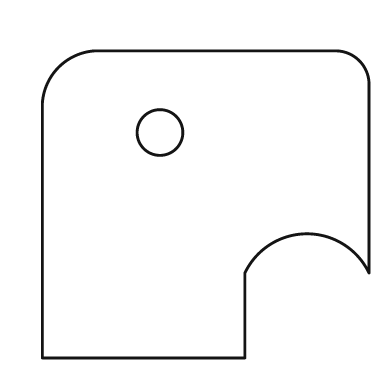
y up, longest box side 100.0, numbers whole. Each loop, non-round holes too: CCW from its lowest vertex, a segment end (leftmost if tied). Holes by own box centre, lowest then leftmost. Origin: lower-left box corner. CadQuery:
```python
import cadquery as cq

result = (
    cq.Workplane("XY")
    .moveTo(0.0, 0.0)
    .lineTo(62.0, 0.0)
    .lineTo(62.0, 26.0)
    .threePointArc((81.0, 38.0), (100.0, 26.0))
    .lineTo(100.0, 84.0)
    .threePointArc((97.0, 91.0), (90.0, 94.0))
    .lineTo(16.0, 94.0)
    .threePointArc((5.0, 89.0), (0.0, 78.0))
    .close()
    .moveTo(36.0, 69.0)
    .circle(7.0)
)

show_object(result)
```